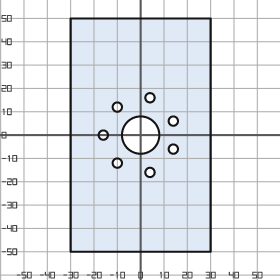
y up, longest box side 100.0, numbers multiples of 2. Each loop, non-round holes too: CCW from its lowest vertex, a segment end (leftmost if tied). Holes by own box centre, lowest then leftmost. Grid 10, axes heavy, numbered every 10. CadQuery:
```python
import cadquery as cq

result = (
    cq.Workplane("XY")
    .moveTo(-30.0, -50.0)
    .lineTo(30.0, -50.0)
    .lineTo(30.0, 50.0)
    .lineTo(-30.0, 50.0)
    .close()
    .moveTo(4.0, -16.0)
    .circle(2.0)
    .moveTo(-10.0, -12.0)
    .circle(2.0)
    .moveTo(14.0, -6.0)
    .circle(2.0)
    .moveTo(-16.0, 0.0)
    .circle(2.0)
    .moveTo(0.0, 0.0)
    .circle(8.0)
    .moveTo(14.0, 6.0)
    .circle(2.0)
    .moveTo(-10.0, 12.0)
    .circle(2.0)
    .moveTo(4.0, 16.0)
    .circle(2.0)
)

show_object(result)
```